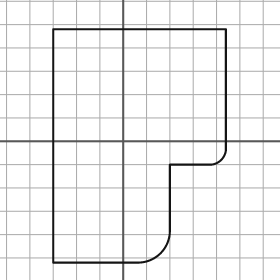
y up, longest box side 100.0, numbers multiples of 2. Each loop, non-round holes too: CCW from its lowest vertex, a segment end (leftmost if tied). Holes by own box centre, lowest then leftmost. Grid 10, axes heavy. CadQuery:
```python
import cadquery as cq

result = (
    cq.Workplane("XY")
    .moveTo(-30.0, -52.0)
    .lineTo(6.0, -52.0)
    .threePointArc((16.0, -48.0), (20.0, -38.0))
    .lineTo(20.0, -10.0)
    .lineTo(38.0, -10.0)
    .threePointArc((42.0, -8.0), (44.0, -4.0))
    .lineTo(44.0, 48.0)
    .lineTo(-30.0, 48.0)
    .close()
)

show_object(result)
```